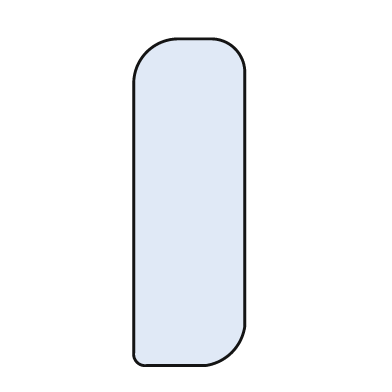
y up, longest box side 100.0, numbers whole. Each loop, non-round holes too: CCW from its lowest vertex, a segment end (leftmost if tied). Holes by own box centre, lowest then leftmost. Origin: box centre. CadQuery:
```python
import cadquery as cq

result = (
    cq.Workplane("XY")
    .moveTo(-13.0, -50.0)
    .lineTo(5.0, -50.0)
    .threePointArc((13.0, -46.0), (17.0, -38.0))
    .lineTo(17.0, 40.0)
    .threePointArc((14.0, 47.0), (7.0, 50.0))
    .lineTo(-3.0, 50.0)
    .threePointArc((-13.0, 46.0), (-17.0, 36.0))
    .lineTo(-17.0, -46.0)
    .threePointArc((-16.0, -49.0), (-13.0, -50.0))
    .close()
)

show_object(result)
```